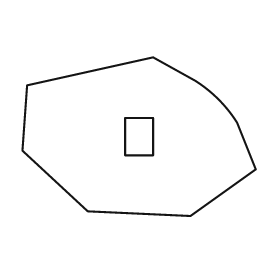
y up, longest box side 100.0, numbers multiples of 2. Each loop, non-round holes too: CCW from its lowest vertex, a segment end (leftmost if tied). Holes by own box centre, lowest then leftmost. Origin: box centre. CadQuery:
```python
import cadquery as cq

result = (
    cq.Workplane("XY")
    .moveTo(22.0, -34.0)
    .lineTo(50.0, -14.0)
    .lineTo(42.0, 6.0)
    .threePointArc((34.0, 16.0), (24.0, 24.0))
    .lineTo(6.0, 34.0)
    .lineTo(-48.0, 22.0)
    .lineTo(-50.0, -6.0)
    .lineTo(-22.0, -32.0)
    .close()
    .moveTo(-6.0, -8.0)
    .lineTo(6.0, -8.0)
    .lineTo(6.0, 8.0)
    .lineTo(-6.0, 8.0)
    .close()
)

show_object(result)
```